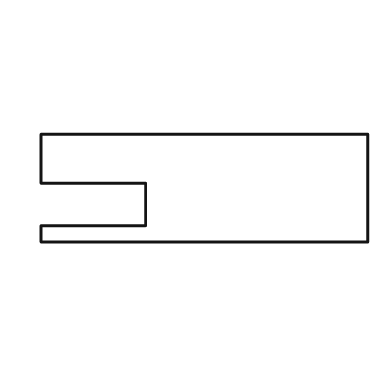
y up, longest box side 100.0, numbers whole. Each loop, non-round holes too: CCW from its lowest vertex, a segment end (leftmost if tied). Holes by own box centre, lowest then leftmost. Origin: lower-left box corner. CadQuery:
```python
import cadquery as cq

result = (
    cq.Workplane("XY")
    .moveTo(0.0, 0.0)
    .lineTo(100.0, 0.0)
    .lineTo(100.0, 33.0)
    .lineTo(0.0, 33.0)
    .lineTo(0.0, 18.0)
    .lineTo(32.0, 18.0)
    .lineTo(32.0, 5.0)
    .lineTo(0.0, 5.0)
    .close()
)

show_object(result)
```